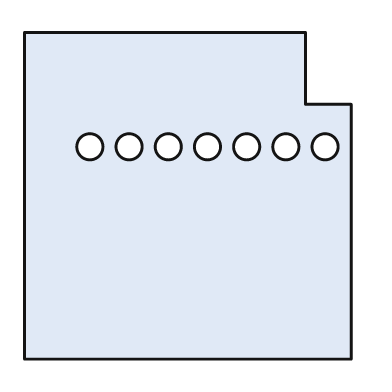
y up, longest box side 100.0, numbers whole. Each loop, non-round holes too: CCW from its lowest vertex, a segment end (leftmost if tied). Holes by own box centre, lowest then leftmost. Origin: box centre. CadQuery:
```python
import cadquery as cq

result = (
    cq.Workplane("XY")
    .moveTo(-50.0, -50.0)
    .lineTo(50.0, -50.0)
    .lineTo(50.0, 28.0)
    .lineTo(36.0, 28.0)
    .lineTo(36.0, 50.0)
    .lineTo(-50.0, 50.0)
    .close()
    .moveTo(-30.0, 15.0)
    .circle(4.0)
    .moveTo(-18.0, 15.0)
    .circle(4.0)
    .moveTo(-6.0, 15.0)
    .circle(4.0)
    .moveTo(6.0, 15.0)
    .circle(4.0)
    .moveTo(18.0, 15.0)
    .circle(4.0)
    .moveTo(30.0, 15.0)
    .circle(4.0)
    .moveTo(42.0, 15.0)
    .circle(4.0)
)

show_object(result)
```